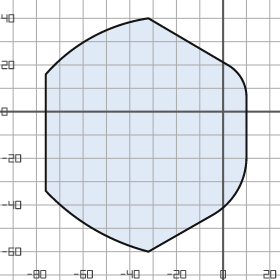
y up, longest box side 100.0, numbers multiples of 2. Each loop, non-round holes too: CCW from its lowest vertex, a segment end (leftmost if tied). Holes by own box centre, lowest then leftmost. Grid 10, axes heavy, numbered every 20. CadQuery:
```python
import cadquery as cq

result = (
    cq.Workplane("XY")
    .moveTo(-32.0, -60.0)
    .lineTo(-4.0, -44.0)
    .threePointArc((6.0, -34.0), (10.0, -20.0))
    .lineTo(10.0, 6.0)
    .threePointArc((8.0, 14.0), (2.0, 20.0))
    .lineTo(-32.0, 40.0)
    .threePointArc((-56.0, 32.0), (-76.0, 16.0))
    .lineTo(-76.0, -34.0)
    .threePointArc((-56.0, -50.0), (-32.0, -60.0))
    .close()
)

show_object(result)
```